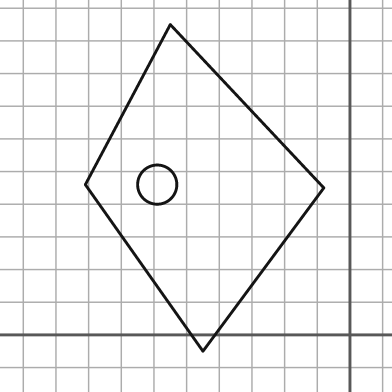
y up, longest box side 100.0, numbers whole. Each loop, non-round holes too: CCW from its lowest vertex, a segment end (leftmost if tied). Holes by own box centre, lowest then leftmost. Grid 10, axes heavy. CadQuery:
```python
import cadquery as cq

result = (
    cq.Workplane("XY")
    .moveTo(-45.0, -5.0)
    .lineTo(-8.0, 45.0)
    .lineTo(-55.0, 95.0)
    .lineTo(-81.0, 46.0)
    .close()
    .moveTo(-59.0, 46.0)
    .circle(6.0)
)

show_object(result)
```